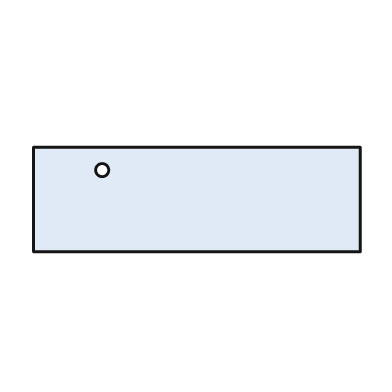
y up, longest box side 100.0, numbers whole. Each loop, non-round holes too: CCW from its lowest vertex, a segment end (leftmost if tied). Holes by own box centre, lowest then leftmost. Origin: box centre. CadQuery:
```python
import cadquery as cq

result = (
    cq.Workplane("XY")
    .moveTo(-50.0, -16.0)
    .lineTo(50.0, -16.0)
    .lineTo(50.0, 16.0)
    .lineTo(-50.0, 16.0)
    .close()
    .moveTo(-29.0, 9.0)
    .circle(2.0)
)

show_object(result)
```